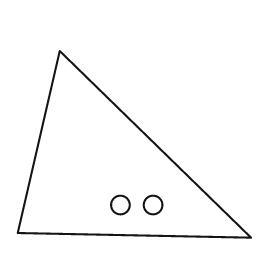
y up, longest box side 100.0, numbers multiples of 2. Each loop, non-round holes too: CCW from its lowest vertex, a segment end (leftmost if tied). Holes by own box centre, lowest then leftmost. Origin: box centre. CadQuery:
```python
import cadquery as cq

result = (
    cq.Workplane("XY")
    .moveTo(50.0, -40.0)
    .lineTo(-32.0, 40.0)
    .lineTo(-50.0, -38.0)
    .close()
    .moveTo(-6.0, -26.0)
    .circle(4.0)
    .moveTo(8.0, -26.0)
    .circle(4.0)
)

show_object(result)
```